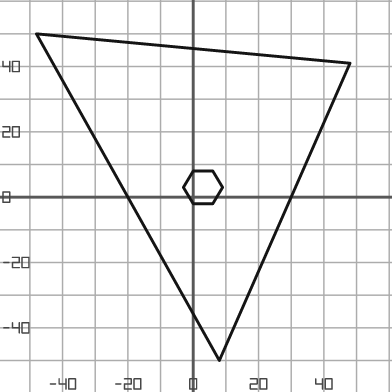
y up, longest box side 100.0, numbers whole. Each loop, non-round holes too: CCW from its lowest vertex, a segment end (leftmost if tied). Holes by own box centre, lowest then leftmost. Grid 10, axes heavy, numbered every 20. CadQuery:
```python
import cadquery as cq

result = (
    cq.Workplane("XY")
    .moveTo(8.0, -50.0)
    .lineTo(48.0, 41.0)
    .lineTo(-48.0, 50.0)
    .close()
    .moveTo(0.0, -2.0)
    .lineTo(6.0, -2.0)
    .lineTo(9.0, 3.0)
    .lineTo(6.0, 8.0)
    .lineTo(0.0, 8.0)
    .lineTo(-3.0, 3.0)
    .close()
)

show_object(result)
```